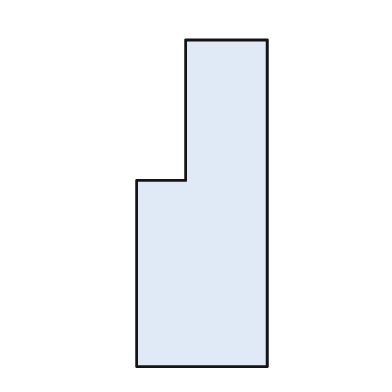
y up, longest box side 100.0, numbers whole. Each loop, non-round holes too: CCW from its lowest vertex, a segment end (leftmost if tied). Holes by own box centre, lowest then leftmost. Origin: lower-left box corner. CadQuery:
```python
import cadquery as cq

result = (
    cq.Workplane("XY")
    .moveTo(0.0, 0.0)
    .lineTo(40.0, 0.0)
    .lineTo(40.0, 100.0)
    .lineTo(15.0, 100.0)
    .lineTo(15.0, 57.0)
    .lineTo(0.0, 57.0)
    .close()
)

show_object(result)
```